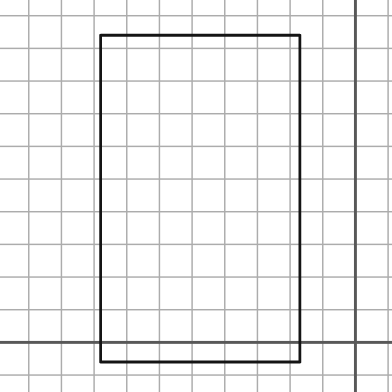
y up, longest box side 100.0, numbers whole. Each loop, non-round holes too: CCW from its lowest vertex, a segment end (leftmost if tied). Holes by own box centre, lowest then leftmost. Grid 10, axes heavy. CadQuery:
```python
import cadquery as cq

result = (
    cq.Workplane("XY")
    .moveTo(-78.0, -6.0)
    .lineTo(-17.0, -6.0)
    .lineTo(-17.0, 94.0)
    .lineTo(-78.0, 94.0)
    .close()
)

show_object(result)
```